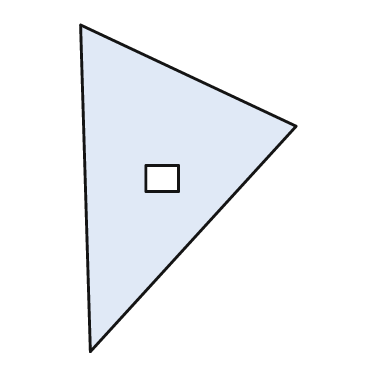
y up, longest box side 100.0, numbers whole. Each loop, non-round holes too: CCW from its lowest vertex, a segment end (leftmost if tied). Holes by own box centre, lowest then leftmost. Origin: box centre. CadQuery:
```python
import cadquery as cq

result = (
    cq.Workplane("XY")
    .moveTo(-30.0, -50.0)
    .lineTo(33.0, 19.0)
    .lineTo(-33.0, 50.0)
    .close()
    .moveTo(-13.0, -1.0)
    .lineTo(-3.0, -1.0)
    .lineTo(-3.0, 7.0)
    .lineTo(-13.0, 7.0)
    .close()
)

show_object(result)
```